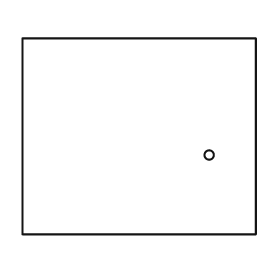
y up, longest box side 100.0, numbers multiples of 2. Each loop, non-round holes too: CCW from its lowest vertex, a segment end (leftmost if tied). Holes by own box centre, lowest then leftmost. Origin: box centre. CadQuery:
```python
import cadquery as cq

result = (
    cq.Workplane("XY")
    .moveTo(-50.0, -42.0)
    .lineTo(50.0, -42.0)
    .lineTo(50.0, 42.0)
    .lineTo(-50.0, 42.0)
    .close()
    .moveTo(30.0, -8.0)
    .circle(2.0)
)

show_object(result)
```